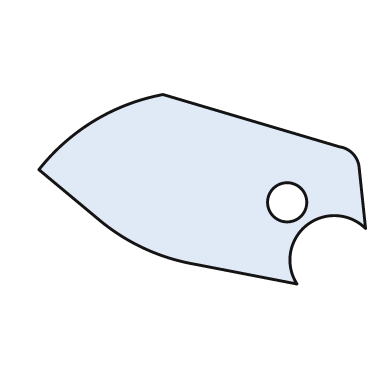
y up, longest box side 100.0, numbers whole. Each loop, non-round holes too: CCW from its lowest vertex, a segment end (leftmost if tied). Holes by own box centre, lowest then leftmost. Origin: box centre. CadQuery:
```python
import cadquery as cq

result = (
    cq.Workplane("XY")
    .moveTo(29.0, -29.0)
    .threePointArc((32.0, -11.0), (50.0, -12.0))
    .lineTo(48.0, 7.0)
    .threePointArc((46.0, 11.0), (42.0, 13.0))
    .lineTo(-12.0, 29.0)
    .threePointArc((-33.0, 21.0), (-50.0, 6.0))
    .lineTo(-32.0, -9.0)
    .threePointArc((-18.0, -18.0), (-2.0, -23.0))
    .close()
    .moveTo(26.0, -4.0)
    .circle(6.0)
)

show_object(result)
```